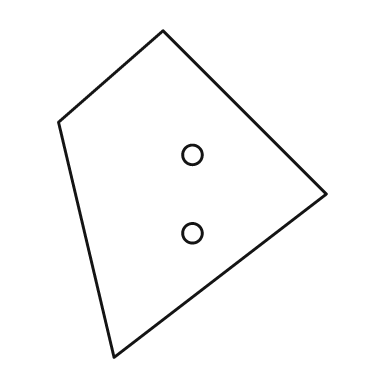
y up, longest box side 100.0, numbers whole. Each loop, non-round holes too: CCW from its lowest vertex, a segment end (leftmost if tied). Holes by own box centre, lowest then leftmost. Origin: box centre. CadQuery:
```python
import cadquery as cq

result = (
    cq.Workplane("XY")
    .moveTo(-24.0, -50.0)
    .lineTo(41.0, 0.0)
    .lineTo(-9.0, 50.0)
    .lineTo(-41.0, 22.0)
    .close()
    .moveTo(0.0, -12.0)
    .circle(3.0)
    .moveTo(0.0, 12.0)
    .circle(3.0)
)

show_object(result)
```